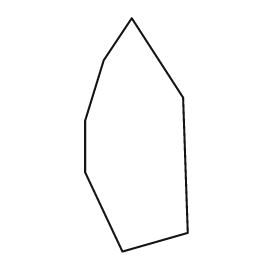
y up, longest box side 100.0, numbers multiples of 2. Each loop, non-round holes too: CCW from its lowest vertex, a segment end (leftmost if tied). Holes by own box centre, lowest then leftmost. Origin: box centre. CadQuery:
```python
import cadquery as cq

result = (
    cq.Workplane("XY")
    .moveTo(-6.0, -50.0)
    .lineTo(22.0, -42.0)
    .lineTo(20.0, 16.0)
    .lineTo(-2.0, 50.0)
    .lineTo(-14.0, 32.0)
    .lineTo(-22.0, 6.0)
    .lineTo(-22.0, -16.0)
    .close()
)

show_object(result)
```